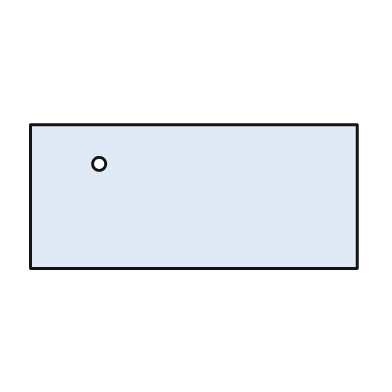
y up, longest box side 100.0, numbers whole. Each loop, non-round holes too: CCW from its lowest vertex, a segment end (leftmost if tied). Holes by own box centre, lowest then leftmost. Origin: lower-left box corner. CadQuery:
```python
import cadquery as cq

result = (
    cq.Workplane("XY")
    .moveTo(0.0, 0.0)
    .lineTo(100.0, 0.0)
    .lineTo(100.0, 44.0)
    .lineTo(0.0, 44.0)
    .close()
    .moveTo(21.0, 32.0)
    .circle(2.0)
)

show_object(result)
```